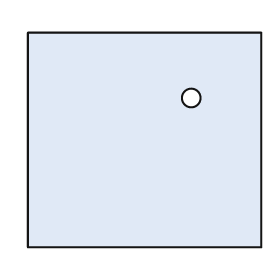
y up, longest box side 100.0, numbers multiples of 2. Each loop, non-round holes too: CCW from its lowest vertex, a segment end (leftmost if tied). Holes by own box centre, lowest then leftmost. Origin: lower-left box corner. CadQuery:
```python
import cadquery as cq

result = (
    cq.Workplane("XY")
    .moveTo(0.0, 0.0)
    .lineTo(100.0, 0.0)
    .lineTo(100.0, 92.0)
    .lineTo(0.0, 92.0)
    .close()
    .moveTo(70.0, 64.0)
    .circle(4.0)
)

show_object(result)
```